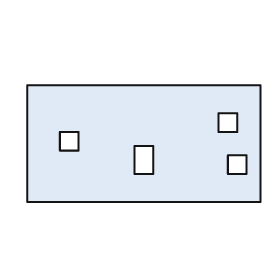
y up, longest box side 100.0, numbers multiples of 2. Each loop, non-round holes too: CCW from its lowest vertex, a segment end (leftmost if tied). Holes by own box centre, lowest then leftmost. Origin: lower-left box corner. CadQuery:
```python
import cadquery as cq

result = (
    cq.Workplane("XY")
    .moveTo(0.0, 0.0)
    .lineTo(100.0, 0.0)
    .lineTo(100.0, 50.0)
    .lineTo(0.0, 50.0)
    .close()
    .moveTo(86.0, 12.0)
    .lineTo(94.0, 12.0)
    .lineTo(94.0, 20.0)
    .lineTo(86.0, 20.0)
    .close()
    .moveTo(46.0, 12.0)
    .lineTo(54.0, 12.0)
    .lineTo(54.0, 24.0)
    .lineTo(46.0, 24.0)
    .close()
    .moveTo(14.0, 22.0)
    .lineTo(22.0, 22.0)
    .lineTo(22.0, 30.0)
    .lineTo(14.0, 30.0)
    .close()
    .moveTo(82.0, 30.0)
    .lineTo(90.0, 30.0)
    .lineTo(90.0, 38.0)
    .lineTo(82.0, 38.0)
    .close()
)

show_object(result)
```